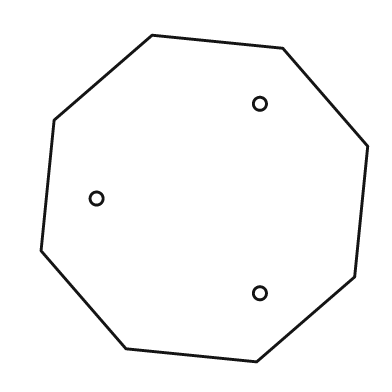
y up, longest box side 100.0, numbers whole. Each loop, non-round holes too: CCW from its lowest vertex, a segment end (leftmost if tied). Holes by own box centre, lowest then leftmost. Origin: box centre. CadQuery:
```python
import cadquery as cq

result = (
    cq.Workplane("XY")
    .moveTo(16.0, -50.0)
    .lineTo(46.0, -24.0)
    .lineTo(50.0, 16.0)
    .lineTo(24.0, 46.0)
    .lineTo(-16.0, 50.0)
    .lineTo(-46.0, 24.0)
    .lineTo(-50.0, -16.0)
    .lineTo(-24.0, -46.0)
    .close()
    .moveTo(17.0, -29.0)
    .circle(2.0)
    .moveTo(-33.0, 0.0)
    .circle(2.0)
    .moveTo(17.0, 29.0)
    .circle(2.0)
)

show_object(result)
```